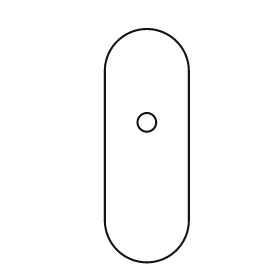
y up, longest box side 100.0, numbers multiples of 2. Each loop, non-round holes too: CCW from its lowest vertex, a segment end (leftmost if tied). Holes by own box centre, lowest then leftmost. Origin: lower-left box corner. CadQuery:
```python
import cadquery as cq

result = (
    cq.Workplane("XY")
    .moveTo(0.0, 18.0)
    .threePointArc((18.0, 0.0), (36.0, 18.0))
    .lineTo(36.0, 82.0)
    .threePointArc((18.0, 100.0), (0.0, 82.0))
    .close()
    .moveTo(18.0, 60.0)
    .circle(4.0)
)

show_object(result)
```